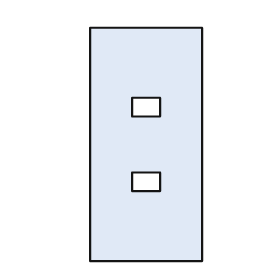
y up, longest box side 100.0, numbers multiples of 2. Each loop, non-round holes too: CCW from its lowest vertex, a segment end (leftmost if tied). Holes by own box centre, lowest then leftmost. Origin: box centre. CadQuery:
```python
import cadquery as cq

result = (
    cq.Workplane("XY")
    .moveTo(-24.0, -50.0)
    .lineTo(24.0, -50.0)
    .lineTo(24.0, 50.0)
    .lineTo(-24.0, 50.0)
    .close()
    .moveTo(-6.0, -20.0)
    .lineTo(6.0, -20.0)
    .lineTo(6.0, -12.0)
    .lineTo(-6.0, -12.0)
    .close()
    .moveTo(-6.0, 12.0)
    .lineTo(6.0, 12.0)
    .lineTo(6.0, 20.0)
    .lineTo(-6.0, 20.0)
    .close()
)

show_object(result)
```